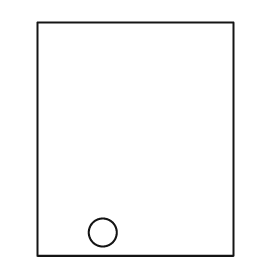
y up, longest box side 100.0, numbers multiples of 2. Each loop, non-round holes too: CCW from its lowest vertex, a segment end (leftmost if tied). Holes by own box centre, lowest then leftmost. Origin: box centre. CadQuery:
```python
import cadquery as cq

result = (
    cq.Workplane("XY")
    .moveTo(-42.0, -50.0)
    .lineTo(42.0, -50.0)
    .lineTo(42.0, 50.0)
    .lineTo(-42.0, 50.0)
    .close()
    .moveTo(-14.0, -40.0)
    .circle(6.0)
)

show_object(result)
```